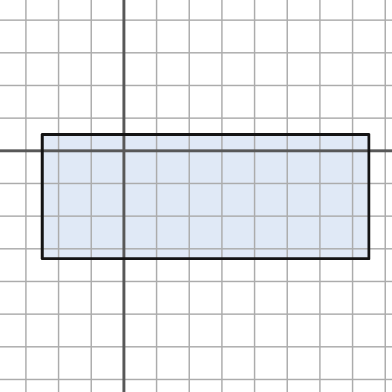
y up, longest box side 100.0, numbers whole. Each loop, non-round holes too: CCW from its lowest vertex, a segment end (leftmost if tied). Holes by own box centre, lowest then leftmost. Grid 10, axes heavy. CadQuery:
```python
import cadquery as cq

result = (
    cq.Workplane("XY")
    .moveTo(-25.0, -33.0)
    .lineTo(75.0, -33.0)
    .lineTo(75.0, 5.0)
    .lineTo(-25.0, 5.0)
    .close()
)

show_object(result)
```